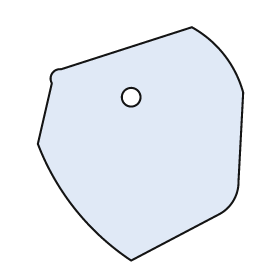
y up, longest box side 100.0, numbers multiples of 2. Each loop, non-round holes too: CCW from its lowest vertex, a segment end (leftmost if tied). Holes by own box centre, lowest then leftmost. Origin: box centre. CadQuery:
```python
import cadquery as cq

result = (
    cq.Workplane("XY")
    .moveTo(-4.0, -50.0)
    .lineTo(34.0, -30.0)
    .threePointArc((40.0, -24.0), (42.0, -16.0))
    .lineTo(44.0, 22.0)
    .threePointArc((36.0, 38.0), (22.0, 50.0))
    .lineTo(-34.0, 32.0)
    .threePointArc((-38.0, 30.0), (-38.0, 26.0))
    .lineTo(-44.0, 0.0)
    .threePointArc((-28.0, -28.0), (-4.0, -50.0))
    .close()
    .moveTo(-4.0, 20.0)
    .circle(4.0)
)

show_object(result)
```